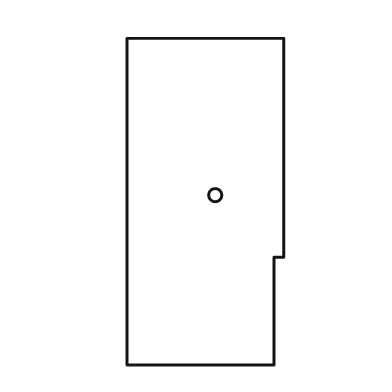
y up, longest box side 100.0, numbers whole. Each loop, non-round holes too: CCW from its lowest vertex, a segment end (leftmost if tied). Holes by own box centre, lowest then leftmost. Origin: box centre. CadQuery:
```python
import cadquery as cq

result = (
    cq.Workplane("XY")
    .moveTo(-24.0, -50.0)
    .lineTo(21.0, -50.0)
    .lineTo(21.0, -17.0)
    .lineTo(24.0, -17.0)
    .lineTo(24.0, 50.0)
    .lineTo(-24.0, 50.0)
    .close()
    .moveTo(3.0, 2.0)
    .circle(2.0)
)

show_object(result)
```